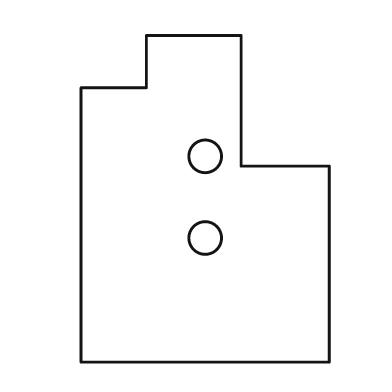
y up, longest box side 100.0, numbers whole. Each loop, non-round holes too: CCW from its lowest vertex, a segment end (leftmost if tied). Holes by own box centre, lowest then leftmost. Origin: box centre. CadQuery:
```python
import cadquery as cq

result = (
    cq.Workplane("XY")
    .moveTo(-38.0, -50.0)
    .lineTo(38.0, -50.0)
    .lineTo(38.0, 10.0)
    .lineTo(11.0, 10.0)
    .lineTo(11.0, 50.0)
    .lineTo(-18.0, 50.0)
    .lineTo(-18.0, 34.0)
    .lineTo(-38.0, 34.0)
    .close()
    .moveTo(0.0, -12.0)
    .circle(5.0)
    .moveTo(0.0, 13.0)
    .circle(5.0)
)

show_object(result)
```